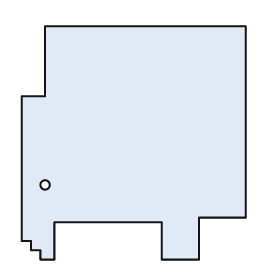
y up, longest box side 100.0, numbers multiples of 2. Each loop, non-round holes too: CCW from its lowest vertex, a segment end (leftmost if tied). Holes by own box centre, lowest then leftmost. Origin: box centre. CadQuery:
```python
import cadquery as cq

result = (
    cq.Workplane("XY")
    .moveTo(-40.0, -50.0)
    .lineTo(-34.0, -50.0)
    .lineTo(-34.0, -34.0)
    .lineTo(12.0, -34.0)
    .lineTo(12.0, -50.0)
    .lineTo(28.0, -50.0)
    .lineTo(28.0, -32.0)
    .lineTo(48.0, -32.0)
    .lineTo(48.0, 50.0)
    .lineTo(-38.0, 50.0)
    .lineTo(-38.0, 20.0)
    .lineTo(-48.0, 20.0)
    .lineTo(-48.0, -42.0)
    .lineTo(-44.0, -42.0)
    .lineTo(-44.0, -46.0)
    .lineTo(-40.0, -46.0)
    .close()
    .moveTo(-38.0, -18.0)
    .circle(2.0)
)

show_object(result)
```